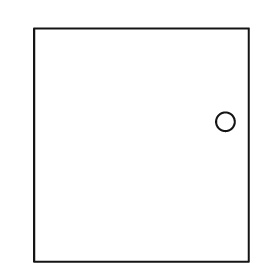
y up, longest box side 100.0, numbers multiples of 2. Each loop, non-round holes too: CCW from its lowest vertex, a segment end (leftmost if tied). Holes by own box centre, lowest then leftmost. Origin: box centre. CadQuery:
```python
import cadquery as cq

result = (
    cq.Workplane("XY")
    .moveTo(-46.0, -50.0)
    .lineTo(46.0, -50.0)
    .lineTo(46.0, 50.0)
    .lineTo(-46.0, 50.0)
    .close()
    .moveTo(36.0, 10.0)
    .circle(4.0)
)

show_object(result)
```